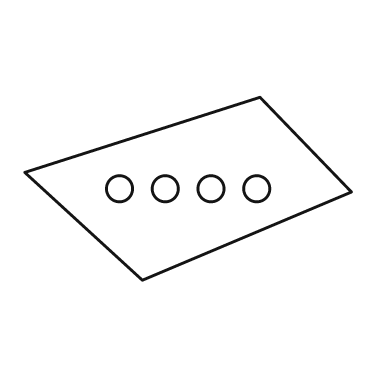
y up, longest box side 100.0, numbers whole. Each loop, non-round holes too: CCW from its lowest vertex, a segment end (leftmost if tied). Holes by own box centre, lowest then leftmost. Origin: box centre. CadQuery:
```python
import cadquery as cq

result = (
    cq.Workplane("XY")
    .moveTo(-14.0, -28.0)
    .lineTo(50.0, -1.0)
    .lineTo(22.0, 28.0)
    .lineTo(-50.0, 5.0)
    .close()
    .moveTo(-21.0, 0.0)
    .circle(4.0)
    .moveTo(-7.0, 0.0)
    .circle(4.0)
    .moveTo(7.0, 0.0)
    .circle(4.0)
    .moveTo(21.0, 0.0)
    .circle(4.0)
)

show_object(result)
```